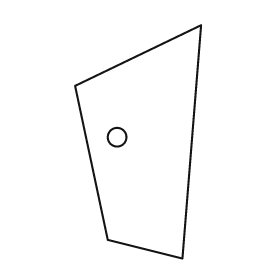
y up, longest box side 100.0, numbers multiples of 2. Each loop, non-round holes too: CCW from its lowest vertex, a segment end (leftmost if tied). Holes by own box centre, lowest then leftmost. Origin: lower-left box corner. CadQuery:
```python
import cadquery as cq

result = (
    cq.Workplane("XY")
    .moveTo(46.0, 0.0)
    .lineTo(54.0, 100.0)
    .lineTo(0.0, 74.0)
    .lineTo(14.0, 8.0)
    .close()
    .moveTo(18.0, 52.0)
    .circle(4.0)
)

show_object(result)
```